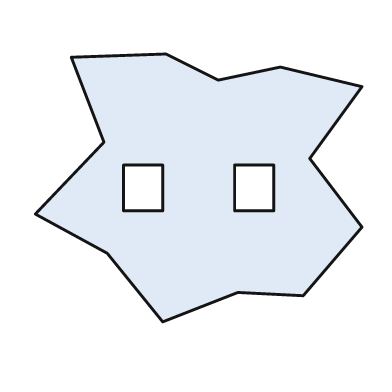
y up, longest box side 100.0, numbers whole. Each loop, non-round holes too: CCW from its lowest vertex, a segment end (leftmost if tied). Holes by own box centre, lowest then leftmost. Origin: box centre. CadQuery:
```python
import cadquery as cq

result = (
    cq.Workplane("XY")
    .moveTo(-11.0, -41.0)
    .lineTo(12.0, -32.0)
    .lineTo(32.0, -33.0)
    .lineTo(50.0, -12.0)
    .lineTo(34.0, 9.0)
    .lineTo(50.0, 31.0)
    .lineTo(25.0, 37.0)
    .lineTo(6.0, 33.0)
    .lineTo(-10.0, 41.0)
    .lineTo(-39.0, 40.0)
    .lineTo(-29.0, 14.0)
    .lineTo(-50.0, -8.0)
    .lineTo(-28.0, -20.0)
    .close()
    .moveTo(-23.0, -7.0)
    .lineTo(-11.0, -7.0)
    .lineTo(-11.0, 7.0)
    .lineTo(-23.0, 7.0)
    .close()
    .moveTo(11.0, -7.0)
    .lineTo(23.0, -7.0)
    .lineTo(23.0, 7.0)
    .lineTo(11.0, 7.0)
    .close()
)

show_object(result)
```